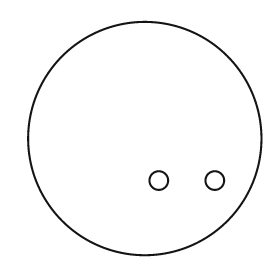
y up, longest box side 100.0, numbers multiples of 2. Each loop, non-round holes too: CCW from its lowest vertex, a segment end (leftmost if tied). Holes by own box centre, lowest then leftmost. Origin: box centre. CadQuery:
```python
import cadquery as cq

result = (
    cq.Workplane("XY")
    .moveTo(0.0, 0.0)
    .circle(50.0)
    .moveTo(6.0, -18.0)
    .circle(4.0)
    .moveTo(30.0, -18.0)
    .circle(4.0)
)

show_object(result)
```